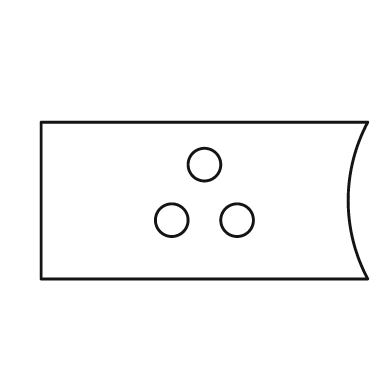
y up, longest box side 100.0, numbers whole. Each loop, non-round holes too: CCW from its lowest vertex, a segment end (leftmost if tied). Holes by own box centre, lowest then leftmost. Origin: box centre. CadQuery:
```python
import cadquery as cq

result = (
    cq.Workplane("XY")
    .moveTo(-50.0, -24.0)
    .lineTo(50.0, -24.0)
    .threePointArc((44.0, 0.0), (50.0, 24.0))
    .lineTo(-50.0, 24.0)
    .close()
    .moveTo(-10.0, -6.0)
    .circle(5.0)
    .moveTo(10.0, -6.0)
    .circle(5.0)
    .moveTo(0.0, 11.0)
    .circle(5.0)
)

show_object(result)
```